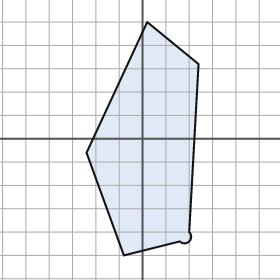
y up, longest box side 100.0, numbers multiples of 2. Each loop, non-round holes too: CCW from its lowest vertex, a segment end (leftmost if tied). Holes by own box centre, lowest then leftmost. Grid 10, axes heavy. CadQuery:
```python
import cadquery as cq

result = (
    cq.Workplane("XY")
    .moveTo(-8.0, -50.0)
    .lineTo(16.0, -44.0)
    .threePointArc((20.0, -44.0), (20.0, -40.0))
    .lineTo(24.0, 32.0)
    .lineTo(2.0, 50.0)
    .lineTo(-24.0, -6.0)
    .close()
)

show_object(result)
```